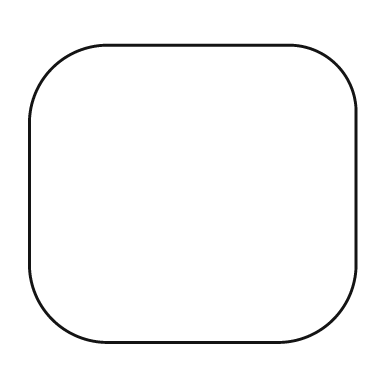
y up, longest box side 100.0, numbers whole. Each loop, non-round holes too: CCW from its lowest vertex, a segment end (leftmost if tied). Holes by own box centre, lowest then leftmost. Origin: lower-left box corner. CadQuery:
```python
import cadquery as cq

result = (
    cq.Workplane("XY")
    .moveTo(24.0, 0.0)
    .lineTo(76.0, 0.0)
    .threePointArc((93.0, 7.0), (100.0, 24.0))
    .lineTo(100.0, 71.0)
    .threePointArc((94.0, 85.0), (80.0, 91.0))
    .lineTo(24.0, 91.0)
    .threePointArc((7.0, 84.0), (0.0, 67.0))
    .lineTo(0.0, 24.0)
    .threePointArc((7.0, 7.0), (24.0, 0.0))
    .close()
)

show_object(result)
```